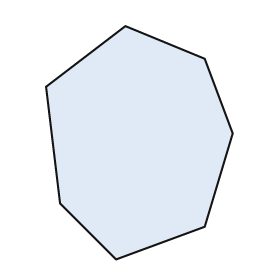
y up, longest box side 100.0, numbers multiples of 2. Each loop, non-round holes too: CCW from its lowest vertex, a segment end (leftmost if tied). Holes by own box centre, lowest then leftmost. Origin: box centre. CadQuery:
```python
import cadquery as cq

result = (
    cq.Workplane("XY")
    .moveTo(-10.0, -50.0)
    .lineTo(28.0, -36.0)
    .lineTo(40.0, 4.0)
    .lineTo(28.0, 36.0)
    .lineTo(-6.0, 50.0)
    .lineTo(-40.0, 24.0)
    .lineTo(-34.0, -26.0)
    .close()
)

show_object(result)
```